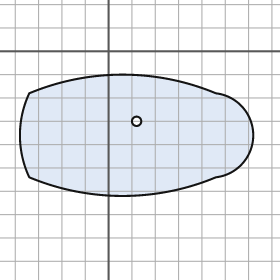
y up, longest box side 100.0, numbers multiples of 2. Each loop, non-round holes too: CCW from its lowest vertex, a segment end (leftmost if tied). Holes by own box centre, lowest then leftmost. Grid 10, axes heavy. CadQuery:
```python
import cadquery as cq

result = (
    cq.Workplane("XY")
    .moveTo(-34.0, -54.0)
    .threePointArc((6.0, -62.0), (46.0, -54.0))
    .threePointArc((62.0, -36.0), (46.0, -18.0))
    .threePointArc((6.0, -10.0), (-34.0, -18.0))
    .threePointArc((-38.0, -36.0), (-34.0, -54.0))
    .close()
    .moveTo(12.0, -30.0)
    .circle(2.0)
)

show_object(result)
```